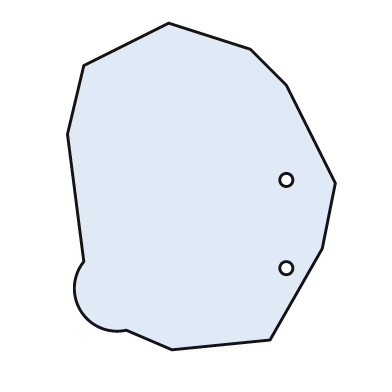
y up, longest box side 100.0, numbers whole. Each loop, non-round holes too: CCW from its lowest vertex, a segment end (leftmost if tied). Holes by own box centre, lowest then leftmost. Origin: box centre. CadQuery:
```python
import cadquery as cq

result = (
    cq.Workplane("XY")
    .moveTo(-9.0, -50.0)
    .lineTo(21.0, -47.0)
    .lineTo(37.0, -19.0)
    .lineTo(41.0, 1.0)
    .lineTo(26.0, 31.0)
    .lineTo(15.0, 42.0)
    .lineTo(-10.0, 50.0)
    .lineTo(-36.0, 37.0)
    .lineTo(-41.0, 16.0)
    .lineTo(-36.0, -23.0)
    .threePointArc((-37.0, -38.0), (-23.0, -44.0))
    .close()
    .moveTo(26.0, -25.0)
    .circle(2.0)
    .moveTo(26.0, 2.0)
    .circle(2.0)
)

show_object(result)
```